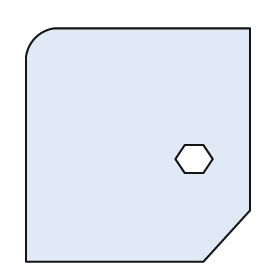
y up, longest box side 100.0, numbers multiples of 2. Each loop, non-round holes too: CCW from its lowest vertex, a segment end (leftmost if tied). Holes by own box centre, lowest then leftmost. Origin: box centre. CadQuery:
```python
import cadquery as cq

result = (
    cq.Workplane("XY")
    .moveTo(-48.0, -50.0)
    .lineTo(28.0, -50.0)
    .lineTo(48.0, -28.0)
    .lineTo(48.0, 50.0)
    .lineTo(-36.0, 50.0)
    .threePointArc((-44.0, 46.0), (-48.0, 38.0))
    .close()
    .moveTo(20.0, -12.0)
    .lineTo(28.0, -12.0)
    .lineTo(32.0, -6.0)
    .lineTo(28.0, 0.0)
    .lineTo(20.0, 0.0)
    .lineTo(16.0, -6.0)
    .close()
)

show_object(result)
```